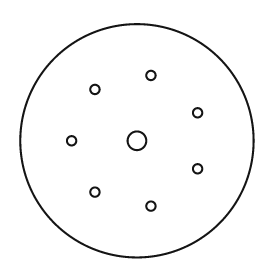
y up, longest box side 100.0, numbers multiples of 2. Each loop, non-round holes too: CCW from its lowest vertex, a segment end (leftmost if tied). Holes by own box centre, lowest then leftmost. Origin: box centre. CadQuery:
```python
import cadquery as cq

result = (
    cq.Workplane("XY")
    .moveTo(0.0, 0.0)
    .circle(50.0)
    .moveTo(6.0, -28.0)
    .circle(2.0)
    .moveTo(-18.0, -22.0)
    .circle(2.0)
    .moveTo(26.0, -12.0)
    .circle(2.0)
    .moveTo(-28.0, 0.0)
    .circle(2.0)
    .moveTo(0.0, 0.0)
    .circle(4.0)
    .moveTo(26.0, 12.0)
    .circle(2.0)
    .moveTo(-18.0, 22.0)
    .circle(2.0)
    .moveTo(6.0, 28.0)
    .circle(2.0)
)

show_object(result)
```